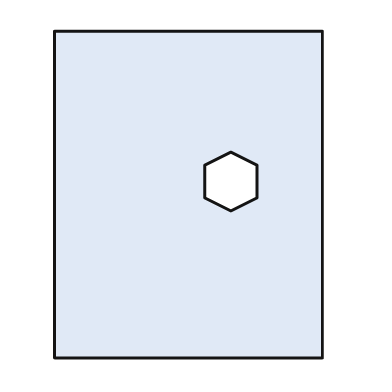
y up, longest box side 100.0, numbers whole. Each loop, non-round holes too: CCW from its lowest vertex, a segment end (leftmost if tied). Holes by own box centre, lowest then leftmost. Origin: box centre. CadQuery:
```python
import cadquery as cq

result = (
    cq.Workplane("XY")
    .moveTo(-41.0, -50.0)
    .lineTo(41.0, -50.0)
    .lineTo(41.0, 50.0)
    .lineTo(-41.0, 50.0)
    .close()
    .moveTo(13.0, -5.0)
    .lineTo(21.0, -1.0)
    .lineTo(21.0, 9.0)
    .lineTo(13.0, 13.0)
    .lineTo(5.0, 9.0)
    .lineTo(5.0, -1.0)
    .close()
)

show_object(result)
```